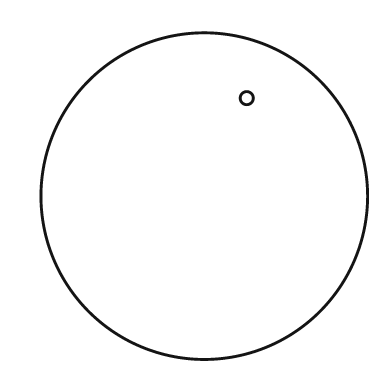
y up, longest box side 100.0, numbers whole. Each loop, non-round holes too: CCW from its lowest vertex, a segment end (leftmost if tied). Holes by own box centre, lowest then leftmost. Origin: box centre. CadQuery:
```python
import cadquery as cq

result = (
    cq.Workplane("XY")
    .moveTo(0.0, 0.0)
    .circle(50.0)
    .moveTo(13.0, 30.0)
    .circle(2.0)
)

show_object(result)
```